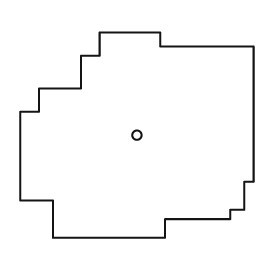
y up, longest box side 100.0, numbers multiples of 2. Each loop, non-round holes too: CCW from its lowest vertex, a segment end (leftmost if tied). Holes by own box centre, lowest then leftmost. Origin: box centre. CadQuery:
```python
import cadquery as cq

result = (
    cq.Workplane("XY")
    .moveTo(-36.0, -44.0)
    .lineTo(12.0, -44.0)
    .lineTo(12.0, -36.0)
    .lineTo(40.0, -36.0)
    .lineTo(40.0, -32.0)
    .lineTo(46.0, -32.0)
    .lineTo(46.0, -20.0)
    .lineTo(50.0, -20.0)
    .lineTo(50.0, 38.0)
    .lineTo(10.0, 38.0)
    .lineTo(10.0, 44.0)
    .lineTo(-16.0, 44.0)
    .lineTo(-16.0, 34.0)
    .lineTo(-24.0, 34.0)
    .lineTo(-24.0, 20.0)
    .lineTo(-42.0, 20.0)
    .lineTo(-42.0, 10.0)
    .lineTo(-50.0, 10.0)
    .lineTo(-50.0, -28.0)
    .lineTo(-36.0, -28.0)
    .close()
    .moveTo(0.0, 0.0)
    .circle(2.0)
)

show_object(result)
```